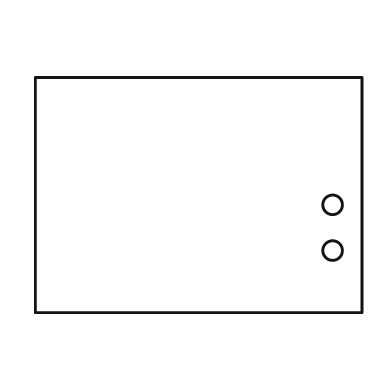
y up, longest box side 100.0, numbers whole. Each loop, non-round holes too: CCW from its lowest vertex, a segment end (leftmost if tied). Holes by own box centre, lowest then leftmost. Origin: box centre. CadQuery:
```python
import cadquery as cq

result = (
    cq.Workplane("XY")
    .moveTo(-50.0, -36.0)
    .lineTo(50.0, -36.0)
    .lineTo(50.0, 36.0)
    .lineTo(-50.0, 36.0)
    .close()
    .moveTo(41.0, -17.0)
    .circle(3.0)
    .moveTo(41.0, -3.0)
    .circle(3.0)
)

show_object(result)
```